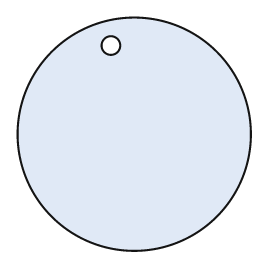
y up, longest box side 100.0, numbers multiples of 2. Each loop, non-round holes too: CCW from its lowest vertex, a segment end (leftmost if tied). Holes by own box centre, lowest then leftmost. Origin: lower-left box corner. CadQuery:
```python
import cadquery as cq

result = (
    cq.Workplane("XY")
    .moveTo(50.0, 50.0)
    .circle(50.0)
    .moveTo(40.0, 88.0)
    .circle(4.0)
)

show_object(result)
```